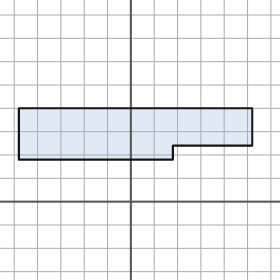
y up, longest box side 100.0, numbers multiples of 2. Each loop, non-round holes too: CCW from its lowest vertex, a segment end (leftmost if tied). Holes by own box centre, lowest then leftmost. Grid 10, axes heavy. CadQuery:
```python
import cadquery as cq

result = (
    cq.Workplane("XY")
    .moveTo(-48.0, 18.0)
    .lineTo(18.0, 18.0)
    .lineTo(18.0, 24.0)
    .lineTo(52.0, 24.0)
    .lineTo(52.0, 40.0)
    .lineTo(-48.0, 40.0)
    .close()
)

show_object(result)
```